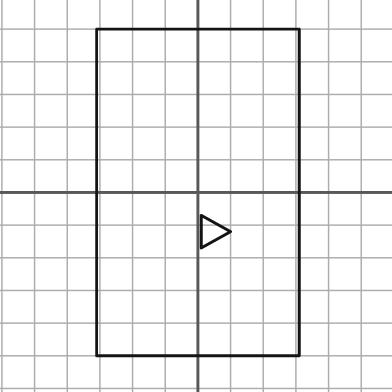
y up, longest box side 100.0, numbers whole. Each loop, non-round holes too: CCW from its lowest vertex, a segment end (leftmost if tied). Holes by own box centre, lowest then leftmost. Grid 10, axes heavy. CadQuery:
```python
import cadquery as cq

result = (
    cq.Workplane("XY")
    .moveTo(-31.0, -50.0)
    .lineTo(31.0, -50.0)
    .lineTo(31.0, 50.0)
    .lineTo(-31.0, 50.0)
    .close()
    .moveTo(1.0, -17.0)
    .lineTo(10.0, -12.0)
    .lineTo(1.0, -7.0)
    .close()
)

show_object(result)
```